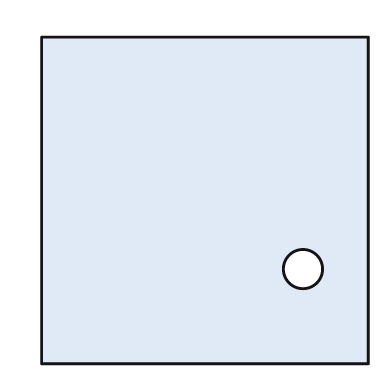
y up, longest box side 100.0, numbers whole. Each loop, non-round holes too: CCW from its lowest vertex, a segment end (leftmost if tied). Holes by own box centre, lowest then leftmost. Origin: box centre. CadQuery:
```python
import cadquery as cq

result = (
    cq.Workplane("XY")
    .moveTo(-50.0, -50.0)
    .lineTo(50.0, -50.0)
    .lineTo(50.0, 50.0)
    .lineTo(-50.0, 50.0)
    .close()
    .moveTo(30.0, -21.0)
    .circle(6.0)
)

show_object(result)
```